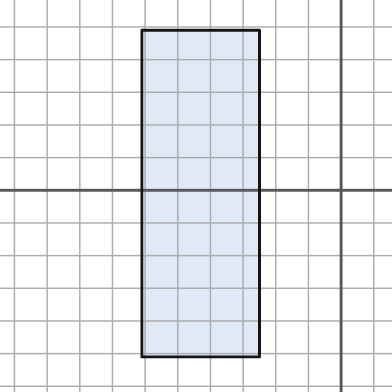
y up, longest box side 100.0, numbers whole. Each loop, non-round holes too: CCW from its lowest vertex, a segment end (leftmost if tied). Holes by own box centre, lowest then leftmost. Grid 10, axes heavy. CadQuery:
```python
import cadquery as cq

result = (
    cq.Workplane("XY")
    .moveTo(-61.0, -51.0)
    .lineTo(-25.0, -51.0)
    .lineTo(-25.0, 49.0)
    .lineTo(-61.0, 49.0)
    .close()
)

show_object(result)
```